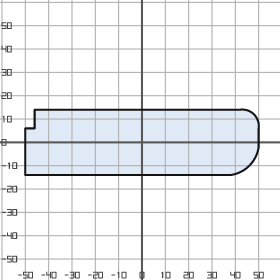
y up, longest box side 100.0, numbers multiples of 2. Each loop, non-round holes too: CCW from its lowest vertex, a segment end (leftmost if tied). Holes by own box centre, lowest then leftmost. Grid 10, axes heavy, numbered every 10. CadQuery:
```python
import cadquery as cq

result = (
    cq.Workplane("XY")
    .moveTo(-50.0, -14.0)
    .lineTo(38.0, -14.0)
    .threePointArc((46.0, -10.0), (50.0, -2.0))
    .lineTo(50.0, 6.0)
    .threePointArc((48.0, 12.0), (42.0, 14.0))
    .lineTo(-46.0, 14.0)
    .lineTo(-46.0, 6.0)
    .lineTo(-50.0, 6.0)
    .close()
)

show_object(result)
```